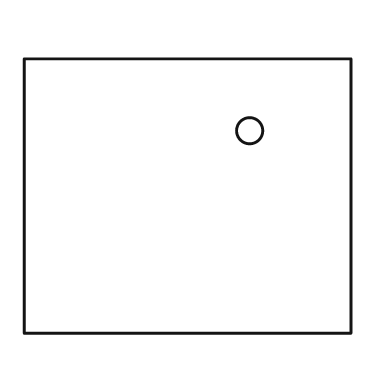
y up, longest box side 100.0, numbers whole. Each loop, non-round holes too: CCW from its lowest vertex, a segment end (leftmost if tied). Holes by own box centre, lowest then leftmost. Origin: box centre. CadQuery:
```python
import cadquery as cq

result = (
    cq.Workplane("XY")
    .moveTo(-50.0, -42.0)
    .lineTo(50.0, -42.0)
    .lineTo(50.0, 42.0)
    .lineTo(-50.0, 42.0)
    .close()
    .moveTo(19.0, 20.0)
    .circle(4.0)
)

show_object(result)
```